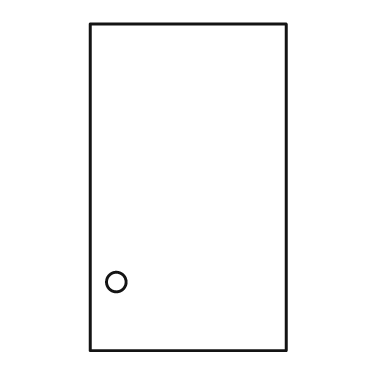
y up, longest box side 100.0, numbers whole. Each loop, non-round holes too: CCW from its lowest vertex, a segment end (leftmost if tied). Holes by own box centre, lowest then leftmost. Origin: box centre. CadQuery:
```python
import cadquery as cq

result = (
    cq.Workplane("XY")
    .moveTo(-30.0, -50.0)
    .lineTo(30.0, -50.0)
    .lineTo(30.0, 50.0)
    .lineTo(-30.0, 50.0)
    .close()
    .moveTo(-22.0, -29.0)
    .circle(3.0)
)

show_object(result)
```